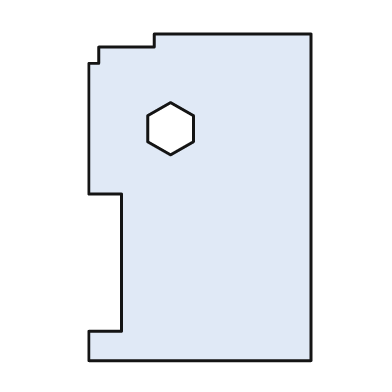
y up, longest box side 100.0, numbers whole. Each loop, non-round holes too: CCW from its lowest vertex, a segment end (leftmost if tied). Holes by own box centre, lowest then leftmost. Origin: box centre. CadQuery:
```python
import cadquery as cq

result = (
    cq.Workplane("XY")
    .moveTo(-34.0, -50.0)
    .lineTo(34.0, -50.0)
    .lineTo(34.0, 50.0)
    .lineTo(-14.0, 50.0)
    .lineTo(-14.0, 46.0)
    .lineTo(-31.0, 46.0)
    .lineTo(-31.0, 41.0)
    .lineTo(-34.0, 41.0)
    .lineTo(-34.0, 1.0)
    .lineTo(-24.0, 1.0)
    .lineTo(-24.0, -41.0)
    .lineTo(-34.0, -41.0)
    .close()
    .moveTo(-9.0, 13.0)
    .lineTo(-2.0, 17.0)
    .lineTo(-2.0, 25.0)
    .lineTo(-9.0, 29.0)
    .lineTo(-16.0, 25.0)
    .lineTo(-16.0, 17.0)
    .close()
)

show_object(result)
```